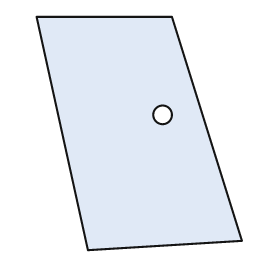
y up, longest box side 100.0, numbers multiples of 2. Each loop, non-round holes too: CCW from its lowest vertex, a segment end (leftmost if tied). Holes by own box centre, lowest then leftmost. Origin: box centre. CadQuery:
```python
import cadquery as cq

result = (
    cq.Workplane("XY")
    .moveTo(-22.0, -50.0)
    .lineTo(44.0, -46.0)
    .lineTo(14.0, 50.0)
    .lineTo(-44.0, 50.0)
    .close()
    .moveTo(10.0, 8.0)
    .circle(4.0)
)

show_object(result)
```